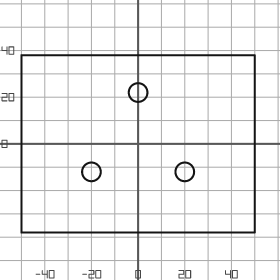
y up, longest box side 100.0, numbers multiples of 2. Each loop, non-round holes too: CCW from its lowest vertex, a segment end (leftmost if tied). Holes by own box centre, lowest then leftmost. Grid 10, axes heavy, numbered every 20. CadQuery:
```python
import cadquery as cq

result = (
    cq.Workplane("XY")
    .moveTo(-50.0, -38.0)
    .lineTo(50.0, -38.0)
    .lineTo(50.0, 38.0)
    .lineTo(-50.0, 38.0)
    .close()
    .moveTo(-20.0, -12.0)
    .circle(4.0)
    .moveTo(20.0, -12.0)
    .circle(4.0)
    .moveTo(0.0, 22.0)
    .circle(4.0)
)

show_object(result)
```